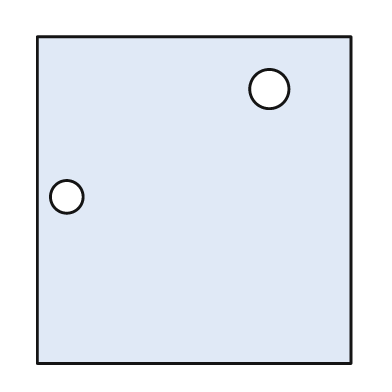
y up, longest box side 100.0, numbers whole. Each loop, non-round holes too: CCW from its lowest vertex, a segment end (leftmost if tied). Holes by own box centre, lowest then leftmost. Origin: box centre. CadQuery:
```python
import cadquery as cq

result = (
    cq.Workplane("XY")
    .moveTo(-48.0, -50.0)
    .lineTo(48.0, -50.0)
    .lineTo(48.0, 50.0)
    .lineTo(-48.0, 50.0)
    .close()
    .moveTo(-39.0, 1.0)
    .circle(5.0)
    .moveTo(23.0, 34.0)
    .circle(6.0)
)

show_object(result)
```